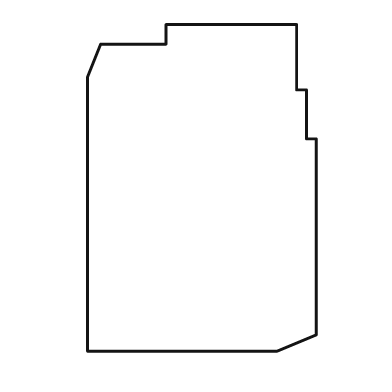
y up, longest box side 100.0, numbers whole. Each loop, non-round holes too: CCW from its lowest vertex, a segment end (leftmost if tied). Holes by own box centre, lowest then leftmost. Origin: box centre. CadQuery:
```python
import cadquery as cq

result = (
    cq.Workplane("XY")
    .moveTo(-35.0, -50.0)
    .lineTo(23.0, -50.0)
    .lineTo(35.0, -45.0)
    .lineTo(35.0, 15.0)
    .lineTo(32.0, 15.0)
    .lineTo(32.0, 30.0)
    .lineTo(29.0, 30.0)
    .lineTo(29.0, 50.0)
    .lineTo(-11.0, 50.0)
    .lineTo(-11.0, 44.0)
    .lineTo(-31.0, 44.0)
    .lineTo(-35.0, 34.0)
    .close()
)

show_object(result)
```